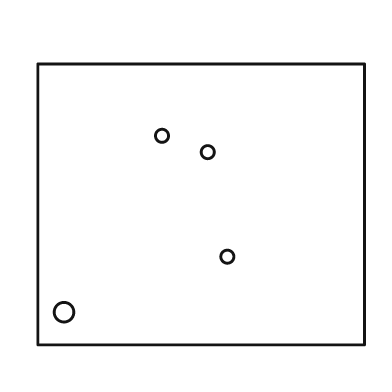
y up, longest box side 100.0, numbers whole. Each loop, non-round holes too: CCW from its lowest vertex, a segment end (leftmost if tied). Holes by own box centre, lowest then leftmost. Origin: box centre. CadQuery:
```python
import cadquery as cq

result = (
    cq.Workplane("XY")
    .moveTo(-50.0, -43.0)
    .lineTo(50.0, -43.0)
    .lineTo(50.0, 43.0)
    .lineTo(-50.0, 43.0)
    .close()
    .moveTo(-42.0, -33.0)
    .circle(3.0)
    .moveTo(8.0, -16.0)
    .circle(2.0)
    .moveTo(2.0, 16.0)
    .circle(2.0)
    .moveTo(-12.0, 21.0)
    .circle(2.0)
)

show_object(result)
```